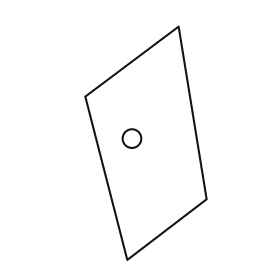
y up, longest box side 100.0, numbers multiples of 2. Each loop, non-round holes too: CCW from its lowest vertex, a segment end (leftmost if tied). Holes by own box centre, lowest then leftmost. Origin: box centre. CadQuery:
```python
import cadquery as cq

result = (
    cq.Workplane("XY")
    .moveTo(-8.0, -50.0)
    .lineTo(26.0, -24.0)
    .lineTo(14.0, 50.0)
    .lineTo(-26.0, 20.0)
    .close()
    .moveTo(-6.0, 2.0)
    .circle(4.0)
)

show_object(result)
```